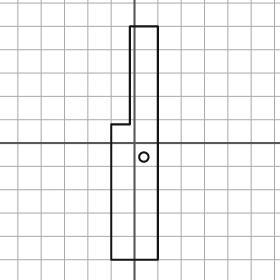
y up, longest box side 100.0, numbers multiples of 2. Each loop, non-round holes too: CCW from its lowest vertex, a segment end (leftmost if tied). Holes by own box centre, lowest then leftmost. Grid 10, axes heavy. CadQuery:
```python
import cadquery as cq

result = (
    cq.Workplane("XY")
    .moveTo(-10.0, -50.0)
    .lineTo(10.0, -50.0)
    .lineTo(10.0, 50.0)
    .lineTo(-2.0, 50.0)
    .lineTo(-2.0, 8.0)
    .lineTo(-10.0, 8.0)
    .close()
    .moveTo(4.0, -6.0)
    .circle(2.0)
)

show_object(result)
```